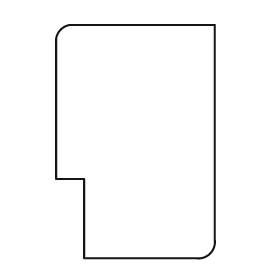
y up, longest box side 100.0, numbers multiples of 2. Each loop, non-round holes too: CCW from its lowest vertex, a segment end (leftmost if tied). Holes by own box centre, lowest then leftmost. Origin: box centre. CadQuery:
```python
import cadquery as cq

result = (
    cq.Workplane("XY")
    .moveTo(-22.0, -50.0)
    .lineTo(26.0, -50.0)
    .threePointArc((32.0, -48.0), (34.0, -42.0))
    .lineTo(34.0, 50.0)
    .lineTo(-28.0, 50.0)
    .threePointArc((-32.0, 48.0), (-34.0, 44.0))
    .lineTo(-34.0, -16.0)
    .lineTo(-22.0, -16.0)
    .close()
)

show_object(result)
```